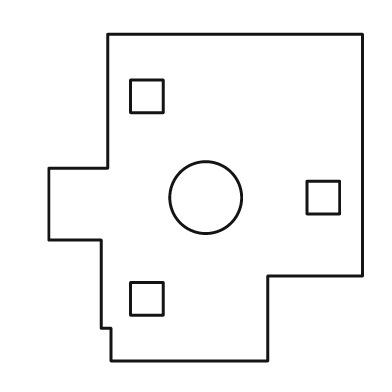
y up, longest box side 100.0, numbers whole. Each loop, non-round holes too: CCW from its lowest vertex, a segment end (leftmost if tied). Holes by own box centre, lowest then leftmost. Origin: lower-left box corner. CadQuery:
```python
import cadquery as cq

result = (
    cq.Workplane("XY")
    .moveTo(19.0, 0.0)
    .lineTo(67.0, 0.0)
    .lineTo(67.0, 26.0)
    .lineTo(96.0, 26.0)
    .lineTo(96.0, 100.0)
    .lineTo(18.0, 100.0)
    .lineTo(18.0, 59.0)
    .lineTo(0.0, 59.0)
    .lineTo(0.0, 37.0)
    .lineTo(16.0, 37.0)
    .lineTo(16.0, 10.0)
    .lineTo(19.0, 10.0)
    .close()
    .moveTo(25.0, 14.0)
    .lineTo(35.0, 14.0)
    .lineTo(35.0, 24.0)
    .lineTo(25.0, 24.0)
    .close()
    .moveTo(48.0, 50.0)
    .circle(11.0)
    .moveTo(79.0, 45.0)
    .lineTo(89.0, 45.0)
    .lineTo(89.0, 55.0)
    .lineTo(79.0, 55.0)
    .close()
    .moveTo(25.0, 76.0)
    .lineTo(35.0, 76.0)
    .lineTo(35.0, 86.0)
    .lineTo(25.0, 86.0)
    .close()
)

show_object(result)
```